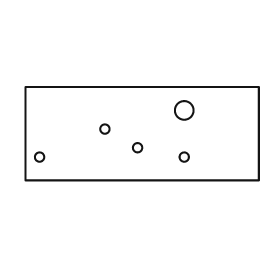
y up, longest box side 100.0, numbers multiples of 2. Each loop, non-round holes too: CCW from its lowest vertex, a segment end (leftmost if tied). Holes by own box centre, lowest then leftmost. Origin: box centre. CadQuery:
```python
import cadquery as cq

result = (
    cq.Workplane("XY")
    .moveTo(-50.0, -20.0)
    .lineTo(50.0, -20.0)
    .lineTo(50.0, 20.0)
    .lineTo(-50.0, 20.0)
    .close()
    .moveTo(-44.0, -10.0)
    .circle(2.0)
    .moveTo(18.0, -10.0)
    .circle(2.0)
    .moveTo(-2.0, -6.0)
    .circle(2.0)
    .moveTo(-16.0, 2.0)
    .circle(2.0)
    .moveTo(18.0, 10.0)
    .circle(4.0)
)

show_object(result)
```